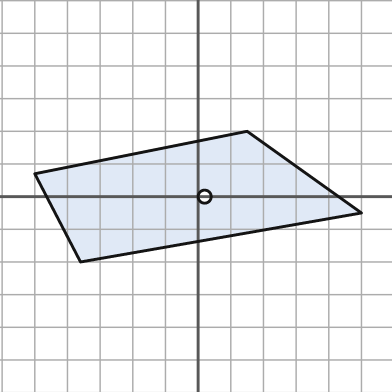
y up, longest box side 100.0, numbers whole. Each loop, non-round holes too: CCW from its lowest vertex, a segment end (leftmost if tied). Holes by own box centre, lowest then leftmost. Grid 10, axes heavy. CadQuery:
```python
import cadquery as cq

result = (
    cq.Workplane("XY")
    .moveTo(-36.0, -20.0)
    .lineTo(50.0, -5.0)
    .lineTo(15.0, 20.0)
    .lineTo(-50.0, 7.0)
    .close()
    .moveTo(2.0, 0.0)
    .circle(2.0)
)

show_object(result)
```